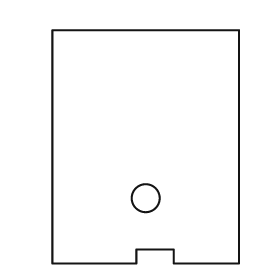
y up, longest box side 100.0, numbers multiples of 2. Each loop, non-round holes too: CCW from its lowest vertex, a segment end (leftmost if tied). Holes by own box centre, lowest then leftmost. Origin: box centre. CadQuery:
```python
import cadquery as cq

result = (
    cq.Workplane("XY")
    .moveTo(-40.0, -50.0)
    .lineTo(-4.0, -50.0)
    .lineTo(-4.0, -44.0)
    .lineTo(12.0, -44.0)
    .lineTo(12.0, -50.0)
    .lineTo(40.0, -50.0)
    .lineTo(40.0, 50.0)
    .lineTo(-40.0, 50.0)
    .close()
    .moveTo(0.0, -22.0)
    .circle(6.0)
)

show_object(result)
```